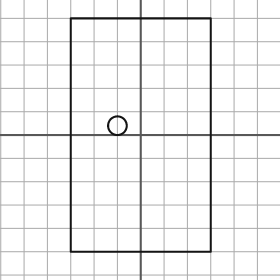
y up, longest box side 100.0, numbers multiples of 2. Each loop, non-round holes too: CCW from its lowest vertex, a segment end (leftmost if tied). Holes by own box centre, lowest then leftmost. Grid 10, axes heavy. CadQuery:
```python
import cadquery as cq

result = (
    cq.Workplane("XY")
    .moveTo(-30.0, -50.0)
    .lineTo(30.0, -50.0)
    .lineTo(30.0, 50.0)
    .lineTo(-30.0, 50.0)
    .close()
    .moveTo(-10.0, 4.0)
    .circle(4.0)
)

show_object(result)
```